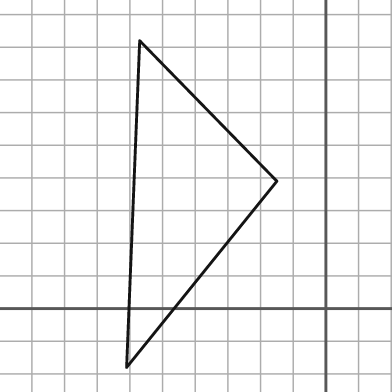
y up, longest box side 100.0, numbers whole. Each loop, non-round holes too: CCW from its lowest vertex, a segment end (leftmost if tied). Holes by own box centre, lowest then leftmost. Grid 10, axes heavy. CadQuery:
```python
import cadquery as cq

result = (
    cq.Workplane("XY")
    .moveTo(-61.0, -18.0)
    .lineTo(-15.0, 39.0)
    .lineTo(-57.0, 82.0)
    .close()
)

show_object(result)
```